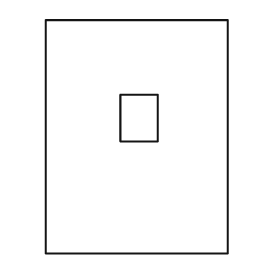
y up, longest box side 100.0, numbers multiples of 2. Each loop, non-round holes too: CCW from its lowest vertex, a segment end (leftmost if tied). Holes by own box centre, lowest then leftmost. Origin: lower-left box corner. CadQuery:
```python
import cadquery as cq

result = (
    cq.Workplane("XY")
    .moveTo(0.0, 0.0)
    .lineTo(78.0, 0.0)
    .lineTo(78.0, 100.0)
    .lineTo(0.0, 100.0)
    .close()
    .moveTo(32.0, 48.0)
    .lineTo(48.0, 48.0)
    .lineTo(48.0, 68.0)
    .lineTo(32.0, 68.0)
    .close()
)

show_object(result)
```